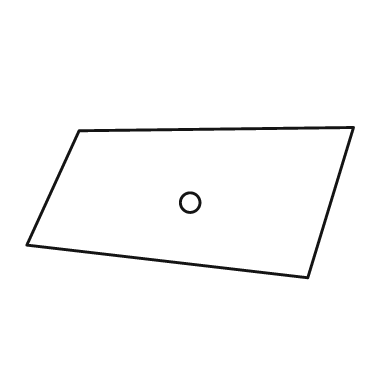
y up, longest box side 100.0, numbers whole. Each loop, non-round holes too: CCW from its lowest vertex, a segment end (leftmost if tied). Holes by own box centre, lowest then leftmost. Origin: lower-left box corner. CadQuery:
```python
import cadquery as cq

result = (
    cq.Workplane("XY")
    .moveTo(86.0, 0.0)
    .lineTo(100.0, 46.0)
    .lineTo(16.0, 45.0)
    .lineTo(0.0, 10.0)
    .close()
    .moveTo(50.0, 23.0)
    .circle(3.0)
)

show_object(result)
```